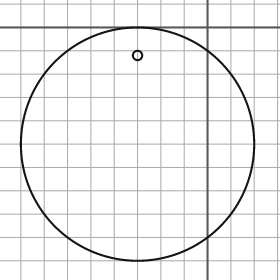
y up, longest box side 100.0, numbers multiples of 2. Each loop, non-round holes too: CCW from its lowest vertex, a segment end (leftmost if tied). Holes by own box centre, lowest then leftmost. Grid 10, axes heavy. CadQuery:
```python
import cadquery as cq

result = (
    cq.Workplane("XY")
    .moveTo(-30.0, -50.0)
    .circle(50.0)
    .moveTo(-30.0, -12.0)
    .circle(2.0)
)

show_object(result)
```